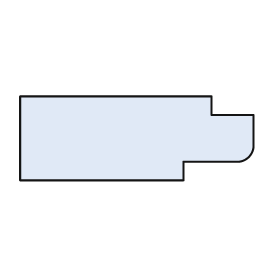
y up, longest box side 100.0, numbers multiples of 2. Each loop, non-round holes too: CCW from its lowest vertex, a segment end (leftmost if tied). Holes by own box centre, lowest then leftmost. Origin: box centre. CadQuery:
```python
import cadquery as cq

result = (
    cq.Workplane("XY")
    .moveTo(-50.0, -18.0)
    .lineTo(20.0, -18.0)
    .lineTo(20.0, -10.0)
    .lineTo(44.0, -10.0)
    .threePointArc((48.0, -8.0), (50.0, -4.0))
    .lineTo(50.0, 10.0)
    .lineTo(32.0, 10.0)
    .lineTo(32.0, 18.0)
    .lineTo(-50.0, 18.0)
    .close()
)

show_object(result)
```